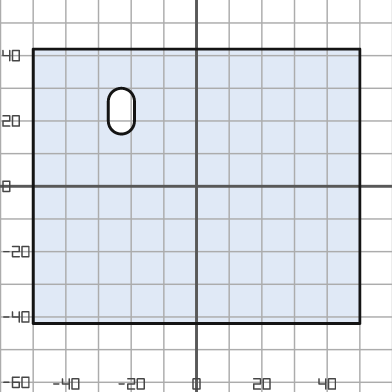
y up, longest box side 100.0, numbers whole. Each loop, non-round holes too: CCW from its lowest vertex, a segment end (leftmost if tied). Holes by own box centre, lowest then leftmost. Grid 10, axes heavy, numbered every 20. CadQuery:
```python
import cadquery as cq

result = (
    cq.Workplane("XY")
    .moveTo(-50.0, -42.0)
    .lineTo(50.0, -42.0)
    .lineTo(50.0, 42.0)
    .lineTo(-50.0, 42.0)
    .close()
    .moveTo(-27.0, 20.0)
    .threePointArc((-23.0, 16.0), (-19.0, 20.0))
    .lineTo(-19.0, 26.0)
    .threePointArc((-23.0, 30.0), (-27.0, 26.0))
    .close()
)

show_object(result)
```